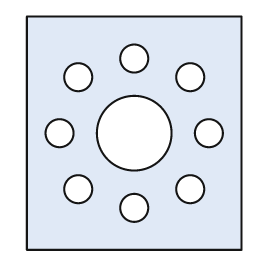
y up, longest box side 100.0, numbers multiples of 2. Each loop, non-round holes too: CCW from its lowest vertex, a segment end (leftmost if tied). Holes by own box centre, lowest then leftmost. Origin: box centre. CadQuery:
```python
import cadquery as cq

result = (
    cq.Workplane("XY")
    .moveTo(-46.0, -50.0)
    .lineTo(46.0, -50.0)
    .lineTo(46.0, 50.0)
    .lineTo(-46.0, 50.0)
    .close()
    .moveTo(0.0, -32.0)
    .circle(6.0)
    .moveTo(-24.0, -24.0)
    .circle(6.0)
    .moveTo(24.0, -24.0)
    .circle(6.0)
    .moveTo(-32.0, 0.0)
    .circle(6.0)
    .moveTo(0.0, 0.0)
    .circle(16.0)
    .moveTo(32.0, 0.0)
    .circle(6.0)
    .moveTo(-24.0, 24.0)
    .circle(6.0)
    .moveTo(24.0, 24.0)
    .circle(6.0)
    .moveTo(0.0, 32.0)
    .circle(6.0)
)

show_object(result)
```